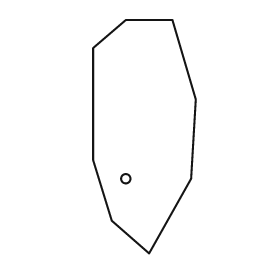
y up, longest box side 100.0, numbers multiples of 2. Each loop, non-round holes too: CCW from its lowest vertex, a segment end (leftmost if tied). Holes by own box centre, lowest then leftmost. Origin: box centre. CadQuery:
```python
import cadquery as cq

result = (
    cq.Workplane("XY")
    .moveTo(2.0, -50.0)
    .lineTo(20.0, -18.0)
    .lineTo(22.0, 16.0)
    .lineTo(12.0, 50.0)
    .lineTo(-8.0, 50.0)
    .lineTo(-22.0, 38.0)
    .lineTo(-22.0, -10.0)
    .lineTo(-14.0, -36.0)
    .close()
    .moveTo(-8.0, -18.0)
    .circle(2.0)
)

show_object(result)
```